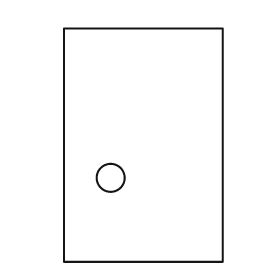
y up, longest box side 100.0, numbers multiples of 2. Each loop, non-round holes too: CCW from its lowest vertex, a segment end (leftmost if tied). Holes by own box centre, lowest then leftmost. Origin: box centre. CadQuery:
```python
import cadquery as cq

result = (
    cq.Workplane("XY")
    .moveTo(-34.0, -50.0)
    .lineTo(34.0, -50.0)
    .lineTo(34.0, 50.0)
    .lineTo(-34.0, 50.0)
    .close()
    .moveTo(-14.0, -14.0)
    .circle(6.0)
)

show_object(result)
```